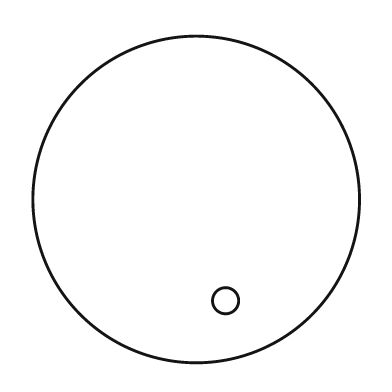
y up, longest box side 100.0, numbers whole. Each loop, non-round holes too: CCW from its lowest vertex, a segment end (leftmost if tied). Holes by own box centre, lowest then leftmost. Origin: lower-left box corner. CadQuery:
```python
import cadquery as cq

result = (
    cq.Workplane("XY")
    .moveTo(50.0, 50.0)
    .circle(50.0)
    .moveTo(59.0, 19.0)
    .circle(4.0)
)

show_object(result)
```